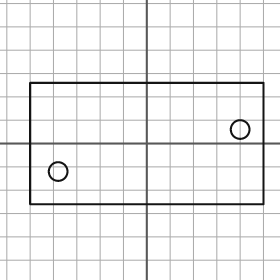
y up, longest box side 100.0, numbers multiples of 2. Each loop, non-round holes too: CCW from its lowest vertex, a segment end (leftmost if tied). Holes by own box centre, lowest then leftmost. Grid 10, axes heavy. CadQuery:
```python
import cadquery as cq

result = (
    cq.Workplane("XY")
    .moveTo(-50.0, -26.0)
    .lineTo(50.0, -26.0)
    .lineTo(50.0, 26.0)
    .lineTo(-50.0, 26.0)
    .close()
    .moveTo(-38.0, -12.0)
    .circle(4.0)
    .moveTo(40.0, 6.0)
    .circle(4.0)
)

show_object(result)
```